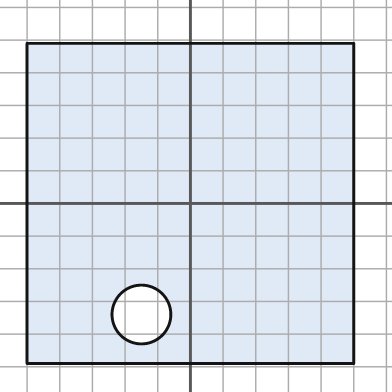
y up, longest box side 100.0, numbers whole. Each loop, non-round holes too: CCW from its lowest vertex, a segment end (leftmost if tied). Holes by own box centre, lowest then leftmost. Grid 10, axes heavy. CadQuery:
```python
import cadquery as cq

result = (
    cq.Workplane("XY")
    .moveTo(-50.0, -49.0)
    .lineTo(50.0, -49.0)
    .lineTo(50.0, 49.0)
    .lineTo(-50.0, 49.0)
    .close()
    .moveTo(-15.0, -34.0)
    .circle(9.0)
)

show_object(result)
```